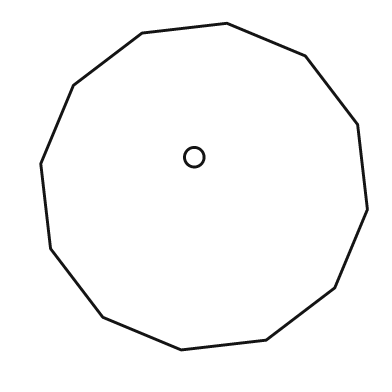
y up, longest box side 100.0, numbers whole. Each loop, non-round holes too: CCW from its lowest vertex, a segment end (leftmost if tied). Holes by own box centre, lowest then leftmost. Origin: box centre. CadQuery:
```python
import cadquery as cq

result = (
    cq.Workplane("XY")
    .moveTo(-7.0, -50.0)
    .lineTo(19.0, -47.0)
    .lineTo(40.0, -31.0)
    .lineTo(50.0, -7.0)
    .lineTo(47.0, 19.0)
    .lineTo(31.0, 40.0)
    .lineTo(7.0, 50.0)
    .lineTo(-19.0, 47.0)
    .lineTo(-40.0, 31.0)
    .lineTo(-50.0, 7.0)
    .lineTo(-47.0, -19.0)
    .lineTo(-31.0, -40.0)
    .close()
    .moveTo(-3.0, 9.0)
    .circle(3.0)
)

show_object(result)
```